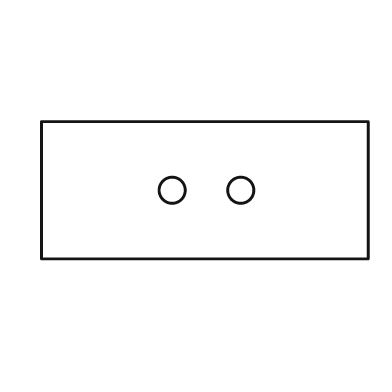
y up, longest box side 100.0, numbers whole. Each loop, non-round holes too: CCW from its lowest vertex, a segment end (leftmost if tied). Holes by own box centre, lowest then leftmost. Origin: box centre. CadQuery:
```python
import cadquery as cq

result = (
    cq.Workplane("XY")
    .moveTo(-50.0, -21.0)
    .lineTo(50.0, -21.0)
    .lineTo(50.0, 21.0)
    .lineTo(-50.0, 21.0)
    .close()
    .moveTo(-10.0, 0.0)
    .circle(4.0)
    .moveTo(11.0, 0.0)
    .circle(4.0)
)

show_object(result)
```